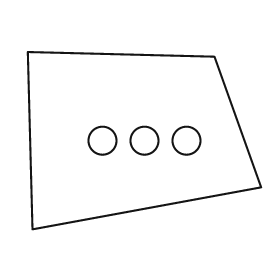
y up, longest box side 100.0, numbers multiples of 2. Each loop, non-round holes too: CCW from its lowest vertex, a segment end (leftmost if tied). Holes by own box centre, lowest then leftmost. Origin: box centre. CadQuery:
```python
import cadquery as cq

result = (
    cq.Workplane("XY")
    .moveTo(-48.0, -38.0)
    .lineTo(50.0, -20.0)
    .lineTo(30.0, 36.0)
    .lineTo(-50.0, 38.0)
    .close()
    .moveTo(-18.0, 0.0)
    .circle(6.0)
    .moveTo(0.0, 0.0)
    .circle(6.0)
    .moveTo(18.0, 0.0)
    .circle(6.0)
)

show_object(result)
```